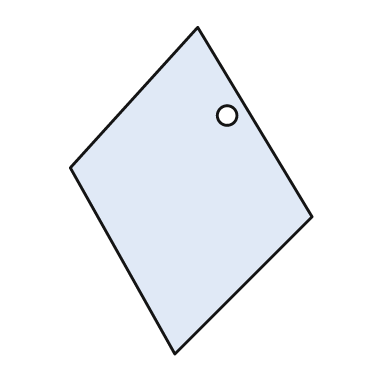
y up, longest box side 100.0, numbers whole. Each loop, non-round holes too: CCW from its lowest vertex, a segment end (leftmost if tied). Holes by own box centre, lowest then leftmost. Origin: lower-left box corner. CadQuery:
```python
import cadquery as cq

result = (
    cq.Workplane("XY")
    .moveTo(32.0, 0.0)
    .lineTo(74.0, 42.0)
    .lineTo(39.0, 100.0)
    .lineTo(0.0, 57.0)
    .close()
    .moveTo(48.0, 73.0)
    .circle(3.0)
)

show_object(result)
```